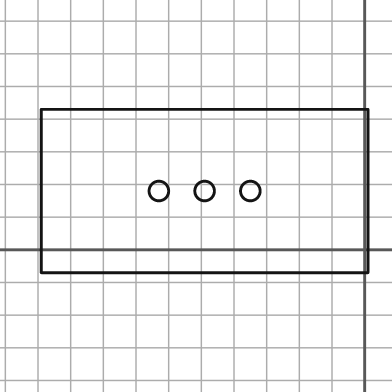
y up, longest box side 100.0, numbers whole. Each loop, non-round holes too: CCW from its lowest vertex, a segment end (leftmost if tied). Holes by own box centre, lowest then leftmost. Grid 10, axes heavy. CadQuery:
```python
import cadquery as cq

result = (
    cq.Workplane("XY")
    .moveTo(-99.0, -7.0)
    .lineTo(1.0, -7.0)
    .lineTo(1.0, 43.0)
    .lineTo(-99.0, 43.0)
    .close()
    .moveTo(-63.0, 18.0)
    .circle(3.0)
    .moveTo(-49.0, 18.0)
    .circle(3.0)
    .moveTo(-35.0, 18.0)
    .circle(3.0)
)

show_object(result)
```